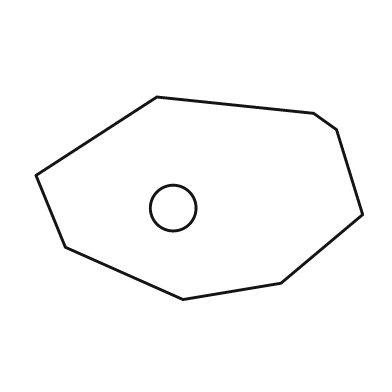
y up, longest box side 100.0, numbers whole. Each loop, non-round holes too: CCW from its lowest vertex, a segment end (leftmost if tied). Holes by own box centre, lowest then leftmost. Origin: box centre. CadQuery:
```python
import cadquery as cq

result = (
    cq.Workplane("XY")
    .moveTo(-5.0, -31.0)
    .lineTo(25.0, -26.0)
    .lineTo(50.0, -5.0)
    .lineTo(42.0, 21.0)
    .lineTo(35.0, 26.0)
    .lineTo(-13.0, 31.0)
    .lineTo(-50.0, 7.0)
    .lineTo(-41.0, -15.0)
    .close()
    .moveTo(-8.0, -3.0)
    .circle(7.0)
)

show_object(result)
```